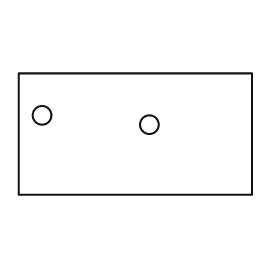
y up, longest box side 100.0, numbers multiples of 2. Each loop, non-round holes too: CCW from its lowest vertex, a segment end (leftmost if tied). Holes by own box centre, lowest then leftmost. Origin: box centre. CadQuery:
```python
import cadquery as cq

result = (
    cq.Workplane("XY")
    .moveTo(-50.0, -26.0)
    .lineTo(50.0, -26.0)
    .lineTo(50.0, 26.0)
    .lineTo(-50.0, 26.0)
    .close()
    .moveTo(6.0, 4.0)
    .circle(4.0)
    .moveTo(-40.0, 8.0)
    .circle(4.0)
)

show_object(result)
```